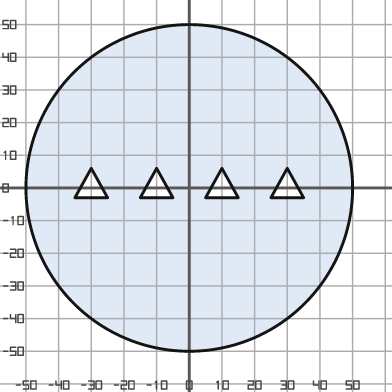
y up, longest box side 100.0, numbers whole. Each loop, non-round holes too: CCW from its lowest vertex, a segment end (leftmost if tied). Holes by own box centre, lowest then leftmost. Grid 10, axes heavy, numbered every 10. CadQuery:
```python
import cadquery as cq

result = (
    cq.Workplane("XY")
    .moveTo(0.0, 0.0)
    .circle(50.0)
    .moveTo(-35.0, -3.0)
    .lineTo(-25.0, -3.0)
    .lineTo(-30.0, 6.0)
    .close()
    .moveTo(-15.0, -3.0)
    .lineTo(-5.0, -3.0)
    .lineTo(-10.0, 6.0)
    .close()
    .moveTo(5.0, -3.0)
    .lineTo(15.0, -3.0)
    .lineTo(10.0, 6.0)
    .close()
    .moveTo(25.0, -3.0)
    .lineTo(35.0, -3.0)
    .lineTo(30.0, 6.0)
    .close()
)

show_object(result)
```